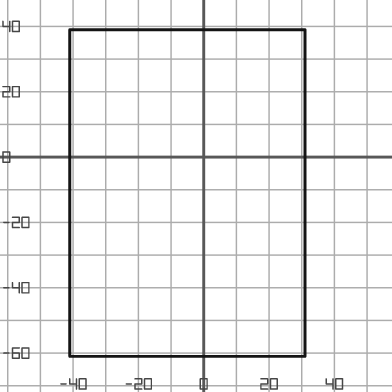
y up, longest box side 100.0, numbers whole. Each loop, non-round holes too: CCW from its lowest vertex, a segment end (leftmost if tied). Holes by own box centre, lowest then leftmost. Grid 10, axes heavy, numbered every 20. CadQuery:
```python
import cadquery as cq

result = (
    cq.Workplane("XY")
    .moveTo(-41.0, -61.0)
    .lineTo(31.0, -61.0)
    .lineTo(31.0, 39.0)
    .lineTo(-41.0, 39.0)
    .close()
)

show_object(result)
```